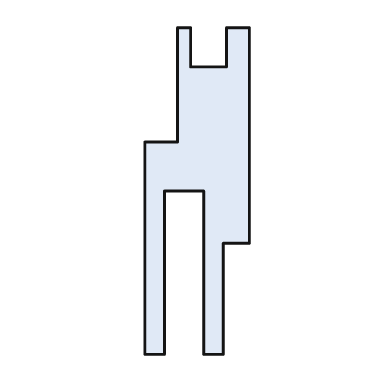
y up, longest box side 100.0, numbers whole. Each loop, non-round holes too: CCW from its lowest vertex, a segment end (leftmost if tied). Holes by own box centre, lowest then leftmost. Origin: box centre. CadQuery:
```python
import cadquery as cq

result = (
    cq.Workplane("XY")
    .moveTo(-16.0, -50.0)
    .lineTo(-10.0, -50.0)
    .lineTo(-10.0, 0.0)
    .lineTo(2.0, 0.0)
    .lineTo(2.0, -50.0)
    .lineTo(8.0, -50.0)
    .lineTo(8.0, -16.0)
    .lineTo(16.0, -16.0)
    .lineTo(16.0, 50.0)
    .lineTo(9.0, 50.0)
    .lineTo(9.0, 38.0)
    .lineTo(-2.0, 38.0)
    .lineTo(-2.0, 50.0)
    .lineTo(-6.0, 50.0)
    .lineTo(-6.0, 15.0)
    .lineTo(-16.0, 15.0)
    .close()
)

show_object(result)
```